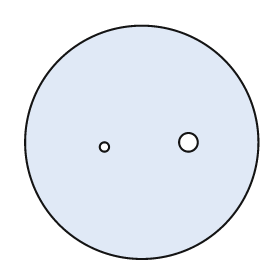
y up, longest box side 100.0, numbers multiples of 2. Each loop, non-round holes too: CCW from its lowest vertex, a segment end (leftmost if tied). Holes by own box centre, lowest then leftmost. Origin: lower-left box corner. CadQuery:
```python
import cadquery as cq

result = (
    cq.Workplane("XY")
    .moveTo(50.0, 50.0)
    .circle(50.0)
    .moveTo(34.0, 48.0)
    .circle(2.0)
    .moveTo(70.0, 50.0)
    .circle(4.0)
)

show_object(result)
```